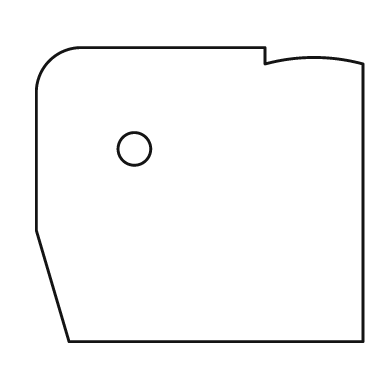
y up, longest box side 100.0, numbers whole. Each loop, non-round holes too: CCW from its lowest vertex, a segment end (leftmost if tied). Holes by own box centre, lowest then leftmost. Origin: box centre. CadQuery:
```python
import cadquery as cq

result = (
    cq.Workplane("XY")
    .moveTo(-40.0, -45.0)
    .lineTo(50.0, -45.0)
    .lineTo(50.0, 40.0)
    .threePointArc((35.0, 42.0), (20.0, 40.0))
    .lineTo(20.0, 45.0)
    .lineTo(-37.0, 45.0)
    .threePointArc((-46.0, 41.0), (-50.0, 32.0))
    .lineTo(-50.0, -11.0)
    .close()
    .moveTo(-20.0, 14.0)
    .circle(5.0)
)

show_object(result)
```